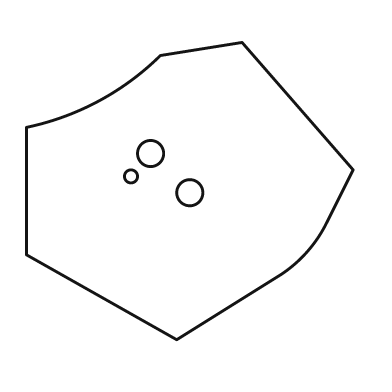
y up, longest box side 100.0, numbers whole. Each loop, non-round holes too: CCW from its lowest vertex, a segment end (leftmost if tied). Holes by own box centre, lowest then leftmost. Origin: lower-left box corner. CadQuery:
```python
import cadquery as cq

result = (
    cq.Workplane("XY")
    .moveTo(46.0, 0.0)
    .lineTo(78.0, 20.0)
    .threePointArc((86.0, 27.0), (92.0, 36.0))
    .lineTo(100.0, 52.0)
    .lineTo(66.0, 91.0)
    .lineTo(41.0, 87.0)
    .threePointArc((22.0, 73.0), (0.0, 65.0))
    .lineTo(0.0, 26.0)
    .close()
    .moveTo(50.0, 45.0)
    .circle(4.0)
    .moveTo(32.0, 50.0)
    .circle(2.0)
    .moveTo(38.0, 57.0)
    .circle(4.0)
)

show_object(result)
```